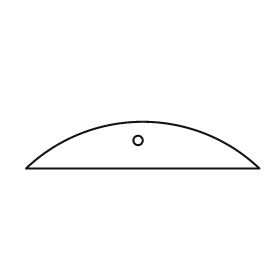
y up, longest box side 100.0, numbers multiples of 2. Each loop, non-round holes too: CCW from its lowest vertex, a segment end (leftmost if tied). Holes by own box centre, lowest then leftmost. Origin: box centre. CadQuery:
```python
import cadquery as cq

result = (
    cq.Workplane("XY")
    .moveTo(-50.0, -10.0)
    .lineTo(50.0, -10.0)
    .threePointArc((0.0, 10.0), (-50.0, -10.0))
    .close()
    .moveTo(-2.0, 2.0)
    .circle(2.0)
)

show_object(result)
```